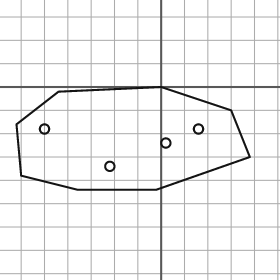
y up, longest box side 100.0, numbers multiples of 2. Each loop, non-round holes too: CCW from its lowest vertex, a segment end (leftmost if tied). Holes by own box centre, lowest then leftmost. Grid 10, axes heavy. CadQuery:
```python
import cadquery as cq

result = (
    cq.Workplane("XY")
    .moveTo(-36.0, -44.0)
    .lineTo(-2.0, -44.0)
    .lineTo(38.0, -30.0)
    .lineTo(30.0, -10.0)
    .lineTo(0.0, 0.0)
    .lineTo(-44.0, -2.0)
    .lineTo(-62.0, -16.0)
    .lineTo(-60.0, -38.0)
    .close()
    .moveTo(-22.0, -34.0)
    .circle(2.0)
    .moveTo(2.0, -24.0)
    .circle(2.0)
    .moveTo(-50.0, -18.0)
    .circle(2.0)
    .moveTo(16.0, -18.0)
    .circle(2.0)
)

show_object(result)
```